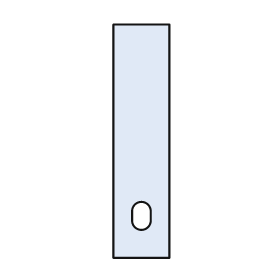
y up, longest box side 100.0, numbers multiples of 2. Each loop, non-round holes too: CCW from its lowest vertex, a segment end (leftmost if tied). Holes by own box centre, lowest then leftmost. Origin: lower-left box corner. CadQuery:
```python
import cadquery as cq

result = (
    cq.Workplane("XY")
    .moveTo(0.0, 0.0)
    .lineTo(24.0, 0.0)
    .lineTo(24.0, 100.0)
    .lineTo(0.0, 100.0)
    .close()
    .moveTo(8.0, 16.0)
    .threePointArc((12.0, 12.0), (16.0, 16.0))
    .lineTo(16.0, 20.0)
    .threePointArc((12.0, 24.0), (8.0, 20.0))
    .close()
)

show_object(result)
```